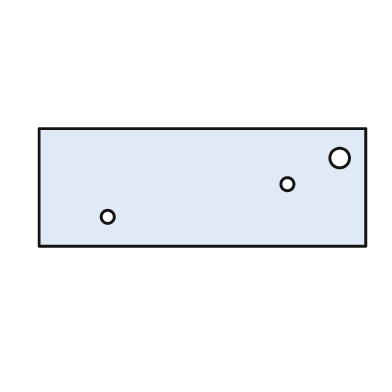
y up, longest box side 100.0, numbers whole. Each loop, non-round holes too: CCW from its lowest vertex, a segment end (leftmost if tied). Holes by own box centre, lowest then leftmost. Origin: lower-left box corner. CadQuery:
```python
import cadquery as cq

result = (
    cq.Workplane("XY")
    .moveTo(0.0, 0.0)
    .lineTo(100.0, 0.0)
    .lineTo(100.0, 36.0)
    .lineTo(0.0, 36.0)
    .close()
    .moveTo(21.0, 9.0)
    .circle(2.0)
    .moveTo(76.0, 19.0)
    .circle(2.0)
    .moveTo(92.0, 27.0)
    .circle(3.0)
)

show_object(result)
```